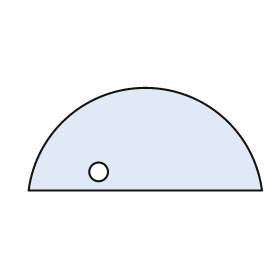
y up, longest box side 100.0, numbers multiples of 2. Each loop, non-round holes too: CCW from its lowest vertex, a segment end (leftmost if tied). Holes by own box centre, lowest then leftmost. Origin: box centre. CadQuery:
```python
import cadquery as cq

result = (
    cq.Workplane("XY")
    .moveTo(-50.0, -22.0)
    .lineTo(50.0, -22.0)
    .threePointArc((0.0, 22.0), (-50.0, -22.0))
    .close()
    .moveTo(-20.0, -14.0)
    .circle(4.0)
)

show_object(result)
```